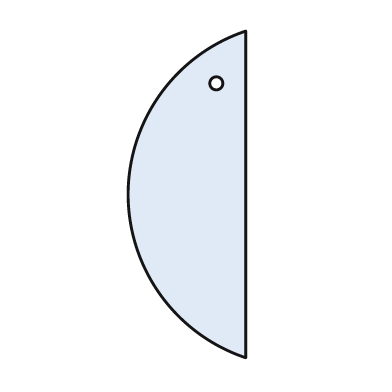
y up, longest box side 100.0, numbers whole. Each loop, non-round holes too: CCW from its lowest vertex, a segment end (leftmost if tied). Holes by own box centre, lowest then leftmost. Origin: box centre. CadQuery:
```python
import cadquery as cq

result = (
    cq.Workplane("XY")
    .moveTo(18.0, -50.0)
    .lineTo(18.0, 50.0)
    .threePointArc((-18.0, 0.0), (18.0, -50.0))
    .close()
    .moveTo(9.0, 34.0)
    .circle(2.0)
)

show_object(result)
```